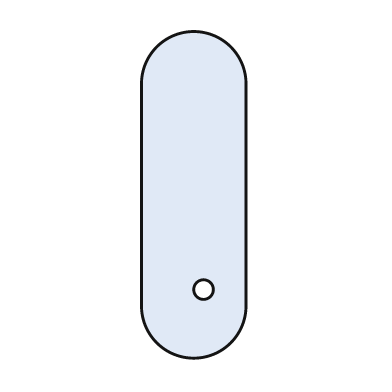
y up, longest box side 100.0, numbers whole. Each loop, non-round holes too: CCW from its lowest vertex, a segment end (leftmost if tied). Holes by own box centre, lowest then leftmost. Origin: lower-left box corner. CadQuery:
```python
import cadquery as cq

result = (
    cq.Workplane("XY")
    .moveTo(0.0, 16.0)
    .threePointArc((16.0, 0.0), (32.0, 16.0))
    .lineTo(32.0, 84.0)
    .threePointArc((16.0, 100.0), (0.0, 84.0))
    .close()
    .moveTo(19.0, 21.0)
    .circle(3.0)
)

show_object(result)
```